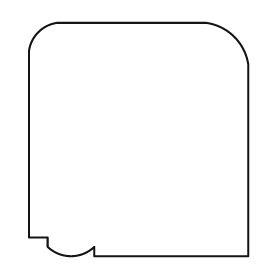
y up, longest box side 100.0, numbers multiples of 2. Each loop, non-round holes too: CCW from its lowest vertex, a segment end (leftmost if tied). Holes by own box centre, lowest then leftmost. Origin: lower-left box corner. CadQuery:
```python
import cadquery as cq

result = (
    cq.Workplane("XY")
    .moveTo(28.0, 0.0)
    .lineTo(94.0, 0.0)
    .lineTo(94.0, 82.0)
    .threePointArc((88.0, 94.0), (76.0, 100.0))
    .lineTo(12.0, 100.0)
    .threePointArc((4.0, 96.0), (0.0, 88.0))
    .lineTo(0.0, 8.0)
    .lineTo(8.0, 8.0)
    .lineTo(8.0, 4.0)
    .threePointArc((18.0, 0.0), (28.0, 4.0))
    .close()
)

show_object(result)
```